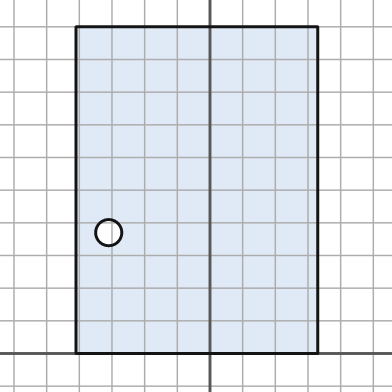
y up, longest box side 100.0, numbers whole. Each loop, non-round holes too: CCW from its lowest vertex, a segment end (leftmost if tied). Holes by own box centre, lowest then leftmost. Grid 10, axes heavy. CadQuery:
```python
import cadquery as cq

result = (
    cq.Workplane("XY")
    .moveTo(-41.0, 0.0)
    .lineTo(33.0, 0.0)
    .lineTo(33.0, 100.0)
    .lineTo(-41.0, 100.0)
    .close()
    .moveTo(-31.0, 37.0)
    .circle(4.0)
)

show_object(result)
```